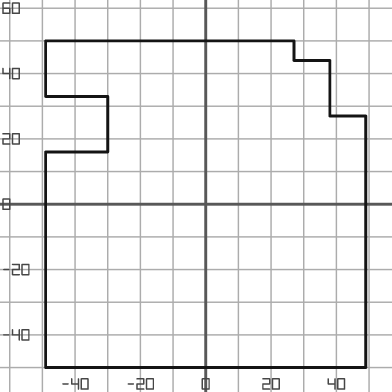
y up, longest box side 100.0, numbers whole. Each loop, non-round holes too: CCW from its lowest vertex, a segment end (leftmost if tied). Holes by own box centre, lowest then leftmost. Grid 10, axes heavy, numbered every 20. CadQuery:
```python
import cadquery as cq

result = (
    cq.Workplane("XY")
    .moveTo(-49.0, -50.0)
    .lineTo(49.0, -50.0)
    .lineTo(49.0, 27.0)
    .lineTo(38.0, 27.0)
    .lineTo(38.0, 44.0)
    .lineTo(27.0, 44.0)
    .lineTo(27.0, 50.0)
    .lineTo(-49.0, 50.0)
    .lineTo(-49.0, 33.0)
    .lineTo(-30.0, 33.0)
    .lineTo(-30.0, 16.0)
    .lineTo(-49.0, 16.0)
    .close()
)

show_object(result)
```